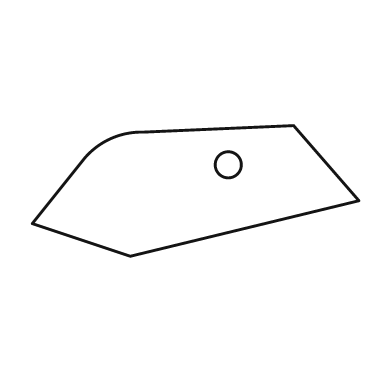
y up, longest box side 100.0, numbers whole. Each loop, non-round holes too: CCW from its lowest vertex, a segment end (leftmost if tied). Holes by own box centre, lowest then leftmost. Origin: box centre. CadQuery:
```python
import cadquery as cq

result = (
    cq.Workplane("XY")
    .moveTo(-20.0, -20.0)
    .lineTo(50.0, -3.0)
    .lineTo(30.0, 20.0)
    .lineTo(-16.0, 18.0)
    .threePointArc((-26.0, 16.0), (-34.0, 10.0))
    .lineTo(-50.0, -10.0)
    .close()
    .moveTo(10.0, 8.0)
    .circle(4.0)
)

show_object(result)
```